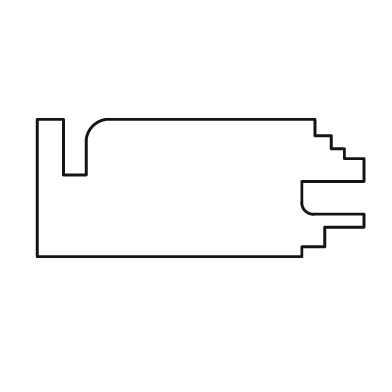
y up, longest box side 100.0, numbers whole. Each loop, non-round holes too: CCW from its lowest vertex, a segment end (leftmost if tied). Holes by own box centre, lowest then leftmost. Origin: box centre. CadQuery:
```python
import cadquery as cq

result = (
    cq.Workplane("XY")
    .moveTo(-50.0, -21.0)
    .lineTo(31.0, -21.0)
    .lineTo(31.0, -18.0)
    .lineTo(38.0, -18.0)
    .lineTo(38.0, -12.0)
    .lineTo(50.0, -12.0)
    .lineTo(50.0, -8.0)
    .lineTo(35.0, -8.0)
    .threePointArc((32.0, -7.0), (31.0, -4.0))
    .lineTo(31.0, 2.0)
    .lineTo(50.0, 2.0)
    .lineTo(50.0, 9.0)
    .lineTo(44.0, 9.0)
    .lineTo(44.0, 12.0)
    .lineTo(40.0, 12.0)
    .lineTo(40.0, 16.0)
    .lineTo(35.0, 16.0)
    .lineTo(35.0, 21.0)
    .lineTo(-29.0, 21.0)
    .threePointArc((-33.0, 19.0), (-35.0, 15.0))
    .lineTo(-35.0, 4.0)
    .lineTo(-42.0, 4.0)
    .lineTo(-42.0, 21.0)
    .lineTo(-50.0, 21.0)
    .close()
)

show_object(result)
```